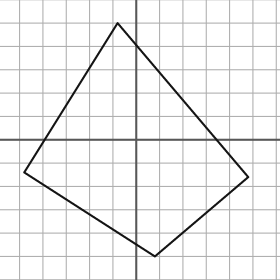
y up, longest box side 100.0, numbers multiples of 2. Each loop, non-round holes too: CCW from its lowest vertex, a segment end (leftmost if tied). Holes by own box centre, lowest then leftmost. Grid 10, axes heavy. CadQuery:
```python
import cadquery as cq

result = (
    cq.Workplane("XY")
    .moveTo(8.0, -50.0)
    .lineTo(48.0, -16.0)
    .lineTo(-8.0, 50.0)
    .lineTo(-48.0, -14.0)
    .close()
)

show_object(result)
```